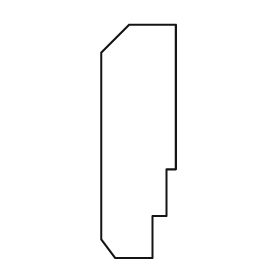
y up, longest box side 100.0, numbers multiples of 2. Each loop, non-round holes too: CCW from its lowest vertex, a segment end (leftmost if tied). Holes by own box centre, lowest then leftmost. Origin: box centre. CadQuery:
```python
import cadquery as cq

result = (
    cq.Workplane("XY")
    .moveTo(-10.0, -50.0)
    .lineTo(6.0, -50.0)
    .lineTo(6.0, -32.0)
    .lineTo(12.0, -32.0)
    .lineTo(12.0, -12.0)
    .lineTo(16.0, -12.0)
    .lineTo(16.0, 50.0)
    .lineTo(-4.0, 50.0)
    .lineTo(-16.0, 38.0)
    .lineTo(-16.0, -42.0)
    .close()
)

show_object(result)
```